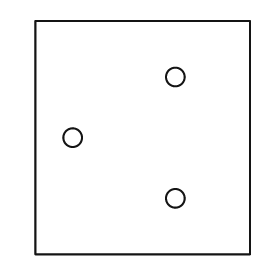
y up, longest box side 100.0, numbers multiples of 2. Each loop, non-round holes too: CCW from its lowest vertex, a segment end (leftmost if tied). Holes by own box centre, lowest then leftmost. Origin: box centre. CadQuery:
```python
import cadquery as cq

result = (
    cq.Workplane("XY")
    .moveTo(-46.0, -50.0)
    .lineTo(46.0, -50.0)
    .lineTo(46.0, 50.0)
    .lineTo(-46.0, 50.0)
    .close()
    .moveTo(14.0, -26.0)
    .circle(4.0)
    .moveTo(-30.0, 0.0)
    .circle(4.0)
    .moveTo(14.0, 26.0)
    .circle(4.0)
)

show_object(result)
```